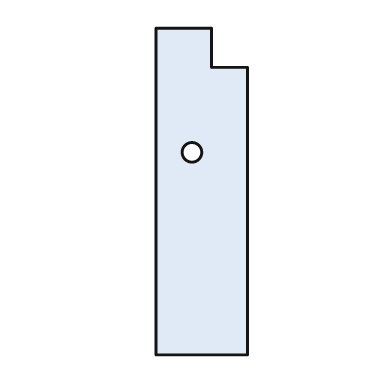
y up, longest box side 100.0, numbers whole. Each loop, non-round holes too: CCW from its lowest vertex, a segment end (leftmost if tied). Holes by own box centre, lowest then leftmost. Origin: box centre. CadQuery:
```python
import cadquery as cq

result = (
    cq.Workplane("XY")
    .moveTo(-14.0, -50.0)
    .lineTo(14.0, -50.0)
    .lineTo(14.0, 38.0)
    .lineTo(3.0, 38.0)
    .lineTo(3.0, 50.0)
    .lineTo(-14.0, 50.0)
    .close()
    .moveTo(-3.0, 12.0)
    .circle(3.0)
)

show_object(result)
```